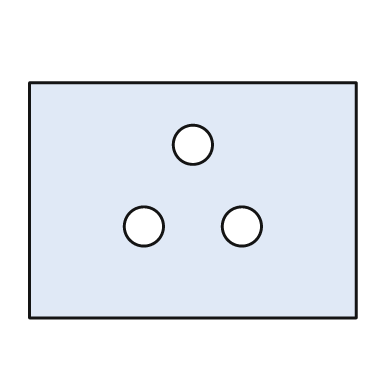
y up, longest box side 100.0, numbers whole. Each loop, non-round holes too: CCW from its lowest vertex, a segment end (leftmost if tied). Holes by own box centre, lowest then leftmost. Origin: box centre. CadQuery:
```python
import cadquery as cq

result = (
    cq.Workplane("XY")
    .moveTo(-50.0, -36.0)
    .lineTo(50.0, -36.0)
    .lineTo(50.0, 36.0)
    .lineTo(-50.0, 36.0)
    .close()
    .moveTo(-15.0, -8.0)
    .circle(6.0)
    .moveTo(15.0, -8.0)
    .circle(6.0)
    .moveTo(0.0, 17.0)
    .circle(6.0)
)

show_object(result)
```